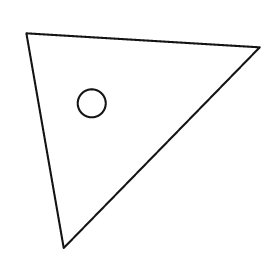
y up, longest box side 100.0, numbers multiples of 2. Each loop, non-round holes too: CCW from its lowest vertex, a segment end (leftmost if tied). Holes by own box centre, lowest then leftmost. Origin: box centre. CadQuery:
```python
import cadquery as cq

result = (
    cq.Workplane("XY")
    .moveTo(-34.0, -46.0)
    .lineTo(50.0, 40.0)
    .lineTo(-50.0, 46.0)
    .close()
    .moveTo(-22.0, 16.0)
    .circle(6.0)
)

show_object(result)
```